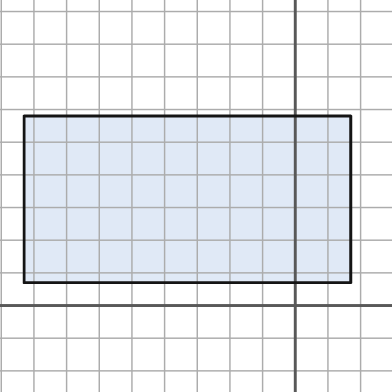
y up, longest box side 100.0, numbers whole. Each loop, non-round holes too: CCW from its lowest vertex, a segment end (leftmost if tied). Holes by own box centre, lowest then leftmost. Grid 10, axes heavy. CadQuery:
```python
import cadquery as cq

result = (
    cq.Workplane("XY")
    .moveTo(-83.0, 7.0)
    .lineTo(17.0, 7.0)
    .lineTo(17.0, 58.0)
    .lineTo(-83.0, 58.0)
    .close()
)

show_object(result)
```